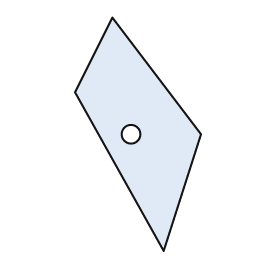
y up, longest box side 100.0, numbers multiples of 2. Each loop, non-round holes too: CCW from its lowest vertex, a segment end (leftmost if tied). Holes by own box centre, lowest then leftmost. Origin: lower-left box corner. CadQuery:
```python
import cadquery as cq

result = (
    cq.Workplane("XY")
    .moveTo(38.0, 0.0)
    .lineTo(54.0, 50.0)
    .lineTo(16.0, 100.0)
    .lineTo(0.0, 68.0)
    .close()
    .moveTo(24.0, 50.0)
    .circle(4.0)
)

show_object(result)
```